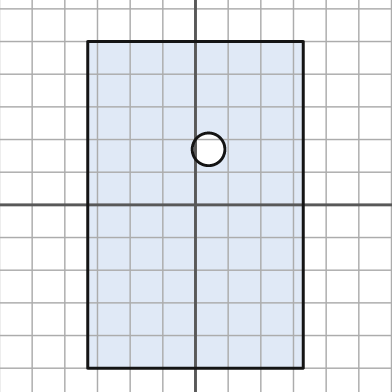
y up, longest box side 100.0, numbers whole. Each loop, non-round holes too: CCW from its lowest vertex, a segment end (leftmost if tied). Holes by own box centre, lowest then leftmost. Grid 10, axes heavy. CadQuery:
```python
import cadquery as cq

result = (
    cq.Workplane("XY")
    .moveTo(-33.0, -50.0)
    .lineTo(33.0, -50.0)
    .lineTo(33.0, 50.0)
    .lineTo(-33.0, 50.0)
    .close()
    .moveTo(4.0, 17.0)
    .circle(5.0)
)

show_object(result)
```